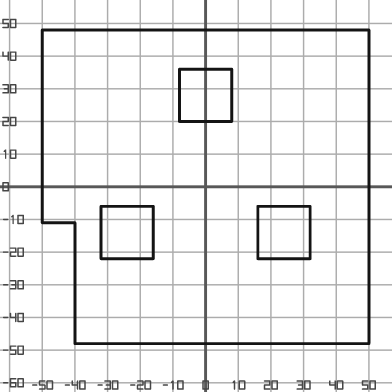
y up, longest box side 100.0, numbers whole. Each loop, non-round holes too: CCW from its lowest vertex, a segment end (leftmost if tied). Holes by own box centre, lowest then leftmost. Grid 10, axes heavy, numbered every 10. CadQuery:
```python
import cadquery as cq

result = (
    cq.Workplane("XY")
    .moveTo(-40.0, -48.0)
    .lineTo(50.0, -48.0)
    .lineTo(50.0, 48.0)
    .lineTo(-50.0, 48.0)
    .lineTo(-50.0, -11.0)
    .lineTo(-40.0, -11.0)
    .close()
    .moveTo(-32.0, -22.0)
    .lineTo(-16.0, -22.0)
    .lineTo(-16.0, -6.0)
    .lineTo(-32.0, -6.0)
    .close()
    .moveTo(16.0, -22.0)
    .lineTo(32.0, -22.0)
    .lineTo(32.0, -6.0)
    .lineTo(16.0, -6.0)
    .close()
    .moveTo(-8.0, 20.0)
    .lineTo(8.0, 20.0)
    .lineTo(8.0, 36.0)
    .lineTo(-8.0, 36.0)
    .close()
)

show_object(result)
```